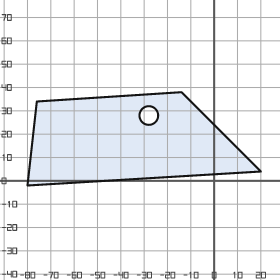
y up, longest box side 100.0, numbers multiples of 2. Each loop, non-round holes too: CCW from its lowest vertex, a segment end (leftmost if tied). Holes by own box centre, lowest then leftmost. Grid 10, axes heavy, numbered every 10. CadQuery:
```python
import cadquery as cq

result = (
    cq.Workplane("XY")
    .moveTo(-80.0, -2.0)
    .lineTo(20.0, 4.0)
    .lineTo(-14.0, 38.0)
    .lineTo(-76.0, 34.0)
    .close()
    .moveTo(-28.0, 28.0)
    .circle(4.0)
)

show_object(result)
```